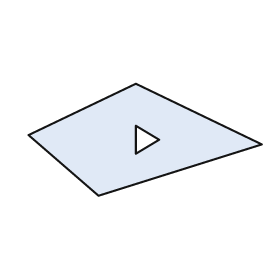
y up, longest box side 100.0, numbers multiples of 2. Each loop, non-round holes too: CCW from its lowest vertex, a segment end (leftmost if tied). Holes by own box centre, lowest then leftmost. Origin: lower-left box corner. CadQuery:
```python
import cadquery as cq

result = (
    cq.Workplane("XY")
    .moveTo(30.0, 0.0)
    .lineTo(100.0, 22.0)
    .lineTo(46.0, 48.0)
    .lineTo(0.0, 26.0)
    .close()
    .moveTo(46.0, 18.0)
    .lineTo(56.0, 24.0)
    .lineTo(46.0, 30.0)
    .close()
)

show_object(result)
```